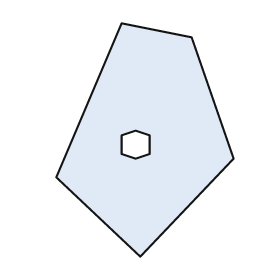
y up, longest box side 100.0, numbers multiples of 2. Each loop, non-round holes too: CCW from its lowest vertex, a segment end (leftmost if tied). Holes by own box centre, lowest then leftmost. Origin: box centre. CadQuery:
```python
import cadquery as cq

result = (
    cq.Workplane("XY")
    .moveTo(-2.0, -50.0)
    .lineTo(38.0, -8.0)
    .lineTo(20.0, 44.0)
    .lineTo(-10.0, 50.0)
    .lineTo(-38.0, -16.0)
    .close()
    .moveTo(-4.0, -8.0)
    .lineTo(2.0, -6.0)
    .lineTo(2.0, 2.0)
    .lineTo(-4.0, 4.0)
    .lineTo(-10.0, 2.0)
    .lineTo(-10.0, -6.0)
    .close()
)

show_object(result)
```